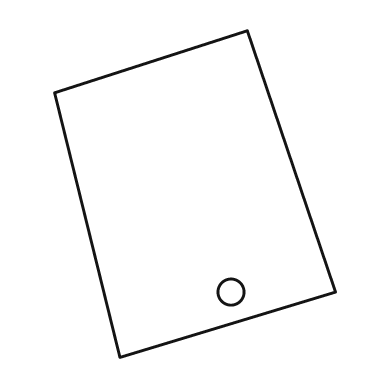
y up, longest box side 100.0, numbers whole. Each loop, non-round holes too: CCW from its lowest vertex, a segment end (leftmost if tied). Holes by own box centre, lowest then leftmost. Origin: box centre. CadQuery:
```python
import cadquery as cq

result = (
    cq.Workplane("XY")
    .moveTo(-23.0, -50.0)
    .lineTo(43.0, -30.0)
    .lineTo(16.0, 50.0)
    .lineTo(-43.0, 31.0)
    .close()
    .moveTo(11.0, -30.0)
    .circle(4.0)
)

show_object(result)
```